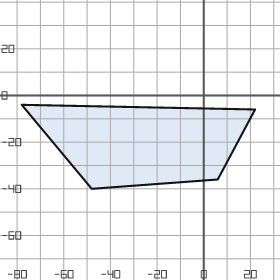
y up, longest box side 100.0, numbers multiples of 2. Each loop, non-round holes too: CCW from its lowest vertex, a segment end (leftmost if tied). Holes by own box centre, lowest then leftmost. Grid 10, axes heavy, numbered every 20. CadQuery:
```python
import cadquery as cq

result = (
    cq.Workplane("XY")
    .moveTo(-48.0, -40.0)
    .lineTo(6.0, -36.0)
    .lineTo(22.0, -6.0)
    .lineTo(-78.0, -4.0)
    .close()
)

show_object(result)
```